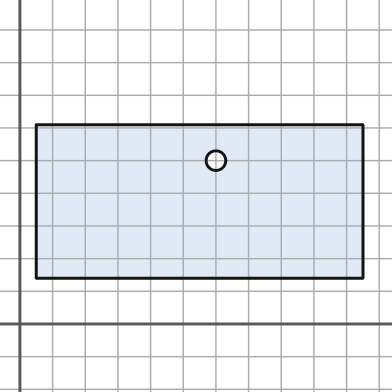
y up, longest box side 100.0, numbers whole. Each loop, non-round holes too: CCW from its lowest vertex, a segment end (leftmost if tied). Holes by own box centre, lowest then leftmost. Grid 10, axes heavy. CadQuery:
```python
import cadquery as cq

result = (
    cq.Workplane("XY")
    .moveTo(5.0, 14.0)
    .lineTo(105.0, 14.0)
    .lineTo(105.0, 61.0)
    .lineTo(5.0, 61.0)
    .close()
    .moveTo(60.0, 50.0)
    .circle(3.0)
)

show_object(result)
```